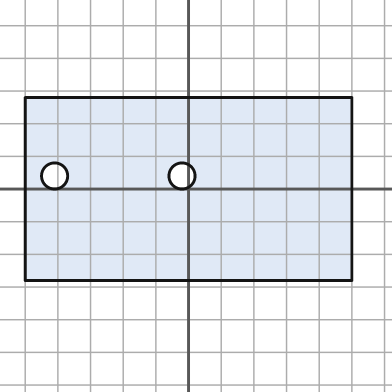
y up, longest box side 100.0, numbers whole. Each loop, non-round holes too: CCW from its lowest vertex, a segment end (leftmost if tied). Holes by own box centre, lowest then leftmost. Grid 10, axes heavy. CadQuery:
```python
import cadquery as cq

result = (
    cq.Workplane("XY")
    .moveTo(-50.0, -28.0)
    .lineTo(50.0, -28.0)
    .lineTo(50.0, 28.0)
    .lineTo(-50.0, 28.0)
    .close()
    .moveTo(-41.0, 4.0)
    .circle(4.0)
    .moveTo(-2.0, 4.0)
    .circle(4.0)
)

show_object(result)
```